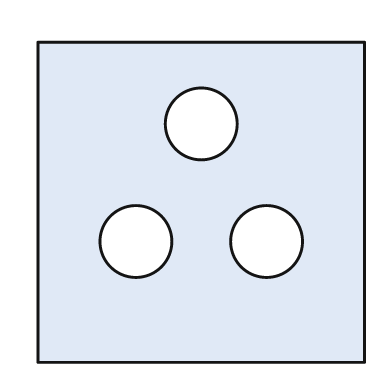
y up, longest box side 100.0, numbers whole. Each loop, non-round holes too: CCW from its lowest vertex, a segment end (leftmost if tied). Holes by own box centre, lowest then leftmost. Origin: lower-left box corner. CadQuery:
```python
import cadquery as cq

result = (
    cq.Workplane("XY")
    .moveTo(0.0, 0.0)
    .lineTo(100.0, 0.0)
    .lineTo(100.0, 98.0)
    .lineTo(0.0, 98.0)
    .close()
    .moveTo(30.0, 37.0)
    .circle(11.0)
    .moveTo(70.0, 37.0)
    .circle(11.0)
    .moveTo(50.0, 73.0)
    .circle(11.0)
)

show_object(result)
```